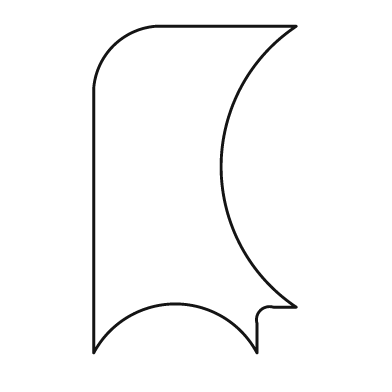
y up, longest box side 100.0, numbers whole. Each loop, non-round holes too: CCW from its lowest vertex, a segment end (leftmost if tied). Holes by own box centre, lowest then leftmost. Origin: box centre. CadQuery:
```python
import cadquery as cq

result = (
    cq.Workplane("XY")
    .moveTo(-31.0, -50.0)
    .threePointArc((-6.0, -35.0), (19.0, -50.0))
    .lineTo(19.0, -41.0)
    .threePointArc((20.0, -37.0), (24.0, -36.0))
    .lineTo(31.0, -36.0)
    .threePointArc((8.0, 7.0), (31.0, 50.0))
    .lineTo(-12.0, 50.0)
    .threePointArc((-25.0, 44.0), (-31.0, 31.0))
    .close()
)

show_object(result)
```